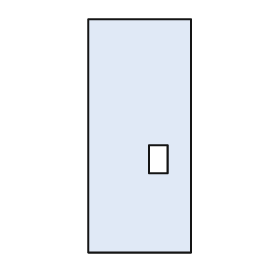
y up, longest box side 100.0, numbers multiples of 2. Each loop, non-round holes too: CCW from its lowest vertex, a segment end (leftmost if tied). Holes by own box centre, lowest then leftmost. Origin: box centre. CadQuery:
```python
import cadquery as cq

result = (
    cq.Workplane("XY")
    .moveTo(-22.0, -50.0)
    .lineTo(22.0, -50.0)
    .lineTo(22.0, 50.0)
    .lineTo(-22.0, 50.0)
    .close()
    .moveTo(4.0, -16.0)
    .lineTo(12.0, -16.0)
    .lineTo(12.0, -4.0)
    .lineTo(4.0, -4.0)
    .close()
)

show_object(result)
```